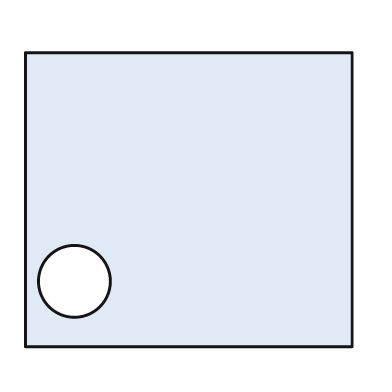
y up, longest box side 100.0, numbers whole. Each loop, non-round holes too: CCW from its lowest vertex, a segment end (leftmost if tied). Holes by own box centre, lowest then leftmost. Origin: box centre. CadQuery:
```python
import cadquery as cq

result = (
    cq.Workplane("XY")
    .moveTo(-50.0, -45.0)
    .lineTo(50.0, -45.0)
    .lineTo(50.0, 45.0)
    .lineTo(-50.0, 45.0)
    .close()
    .moveTo(-35.0, -25.0)
    .circle(11.0)
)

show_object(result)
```